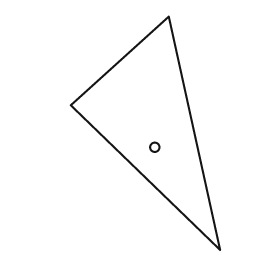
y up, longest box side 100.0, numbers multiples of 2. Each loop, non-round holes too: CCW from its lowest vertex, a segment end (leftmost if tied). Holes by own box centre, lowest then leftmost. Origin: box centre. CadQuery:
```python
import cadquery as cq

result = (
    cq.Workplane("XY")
    .moveTo(32.0, -50.0)
    .lineTo(10.0, 50.0)
    .lineTo(-32.0, 12.0)
    .close()
    .moveTo(4.0, -6.0)
    .circle(2.0)
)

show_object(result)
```